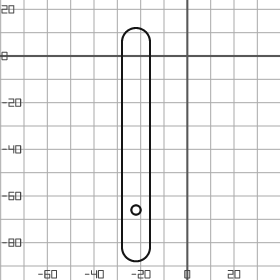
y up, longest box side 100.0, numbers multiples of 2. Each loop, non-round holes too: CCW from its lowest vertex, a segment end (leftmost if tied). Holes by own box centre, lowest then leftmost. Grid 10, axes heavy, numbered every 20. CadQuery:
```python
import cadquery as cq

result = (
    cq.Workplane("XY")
    .moveTo(-28.0, -82.0)
    .threePointArc((-22.0, -88.0), (-16.0, -82.0))
    .lineTo(-16.0, 6.0)
    .threePointArc((-22.0, 12.0), (-28.0, 6.0))
    .close()
    .moveTo(-22.0, -66.0)
    .circle(2.0)
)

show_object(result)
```